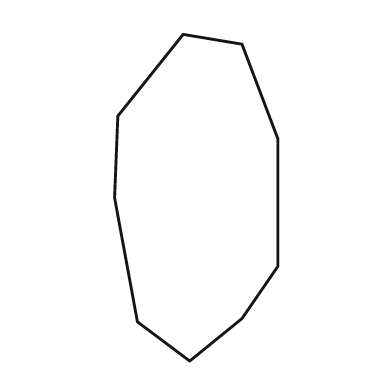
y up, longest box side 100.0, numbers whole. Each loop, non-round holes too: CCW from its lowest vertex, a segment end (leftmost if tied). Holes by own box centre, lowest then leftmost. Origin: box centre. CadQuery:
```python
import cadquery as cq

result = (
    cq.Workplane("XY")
    .moveTo(-2.0, -50.0)
    .lineTo(14.0, -37.0)
    .lineTo(25.0, -21.0)
    .lineTo(25.0, 18.0)
    .lineTo(14.0, 47.0)
    .lineTo(-4.0, 50.0)
    .lineTo(-24.0, 25.0)
    .lineTo(-25.0, 0.0)
    .lineTo(-18.0, -38.0)
    .close()
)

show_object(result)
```